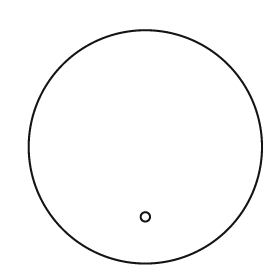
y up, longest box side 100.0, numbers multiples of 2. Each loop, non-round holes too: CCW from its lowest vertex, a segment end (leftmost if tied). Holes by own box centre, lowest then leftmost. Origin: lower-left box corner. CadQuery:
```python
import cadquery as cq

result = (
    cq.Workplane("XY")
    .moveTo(50.0, 50.0)
    .circle(50.0)
    .moveTo(50.0, 20.0)
    .circle(2.0)
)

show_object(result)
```